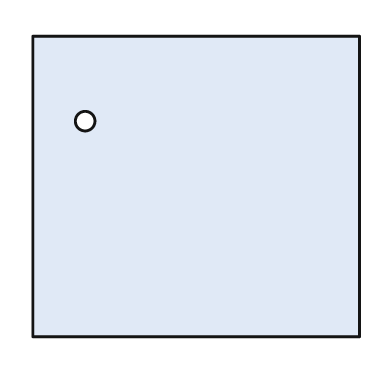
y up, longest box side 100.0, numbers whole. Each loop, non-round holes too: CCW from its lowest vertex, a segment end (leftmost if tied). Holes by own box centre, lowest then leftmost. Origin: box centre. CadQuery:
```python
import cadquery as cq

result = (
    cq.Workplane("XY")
    .moveTo(-50.0, -46.0)
    .lineTo(50.0, -46.0)
    .lineTo(50.0, 46.0)
    .lineTo(-50.0, 46.0)
    .close()
    .moveTo(-34.0, 20.0)
    .circle(3.0)
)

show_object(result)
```